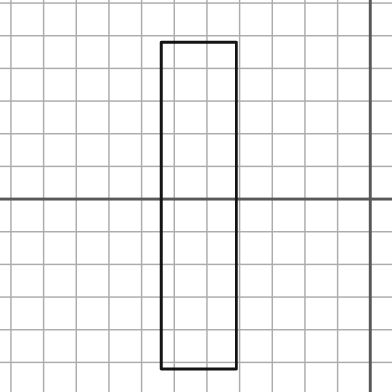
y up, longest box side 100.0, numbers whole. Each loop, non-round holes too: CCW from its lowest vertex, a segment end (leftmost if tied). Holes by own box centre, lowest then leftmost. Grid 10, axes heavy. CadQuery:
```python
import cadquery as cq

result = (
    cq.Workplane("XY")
    .moveTo(-64.0, -52.0)
    .lineTo(-41.0, -52.0)
    .lineTo(-41.0, 48.0)
    .lineTo(-64.0, 48.0)
    .close()
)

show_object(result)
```